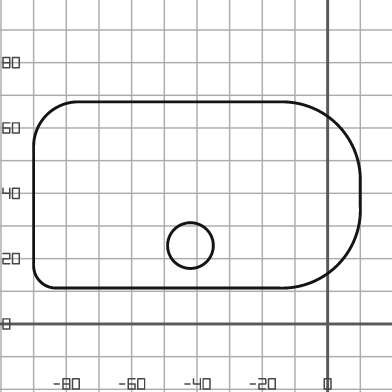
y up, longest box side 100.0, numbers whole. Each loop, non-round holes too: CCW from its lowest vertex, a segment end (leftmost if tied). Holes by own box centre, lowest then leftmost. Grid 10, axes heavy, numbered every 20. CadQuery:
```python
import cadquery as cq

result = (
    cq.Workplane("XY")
    .moveTo(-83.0, 11.0)
    .lineTo(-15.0, 11.0)
    .threePointArc((3.0, 18.0), (10.0, 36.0))
    .lineTo(10.0, 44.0)
    .threePointArc((3.0, 61.0), (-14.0, 68.0))
    .lineTo(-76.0, 68.0)
    .threePointArc((-86.0, 64.0), (-90.0, 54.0))
    .lineTo(-90.0, 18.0)
    .threePointArc((-88.0, 13.0), (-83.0, 11.0))
    .close()
    .moveTo(-42.0, 24.0)
    .circle(7.0)
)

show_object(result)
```